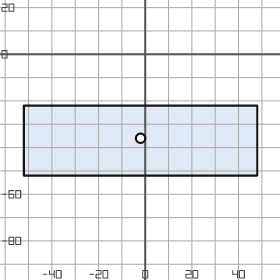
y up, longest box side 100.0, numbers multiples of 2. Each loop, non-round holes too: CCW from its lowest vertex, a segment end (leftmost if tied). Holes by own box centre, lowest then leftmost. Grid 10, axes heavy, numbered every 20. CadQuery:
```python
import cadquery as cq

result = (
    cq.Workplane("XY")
    .moveTo(-52.0, -52.0)
    .lineTo(48.0, -52.0)
    .lineTo(48.0, -22.0)
    .lineTo(-52.0, -22.0)
    .close()
    .moveTo(-2.0, -36.0)
    .circle(2.0)
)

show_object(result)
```